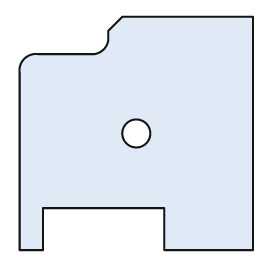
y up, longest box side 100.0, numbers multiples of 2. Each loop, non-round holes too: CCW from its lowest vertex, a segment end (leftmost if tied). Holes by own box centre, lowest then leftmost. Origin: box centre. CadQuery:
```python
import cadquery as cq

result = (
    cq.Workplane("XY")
    .moveTo(-50.0, -50.0)
    .lineTo(-40.0, -50.0)
    .lineTo(-40.0, -32.0)
    .lineTo(12.0, -32.0)
    .lineTo(12.0, -50.0)
    .lineTo(50.0, -50.0)
    .lineTo(50.0, 50.0)
    .lineTo(-6.0, 50.0)
    .lineTo(-12.0, 44.0)
    .lineTo(-12.0, 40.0)
    .threePointArc((-14.0, 36.0), (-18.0, 34.0))
    .lineTo(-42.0, 34.0)
    .threePointArc((-48.0, 32.0), (-50.0, 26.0))
    .close()
    .moveTo(0.0, 0.0)
    .circle(6.0)
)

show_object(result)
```